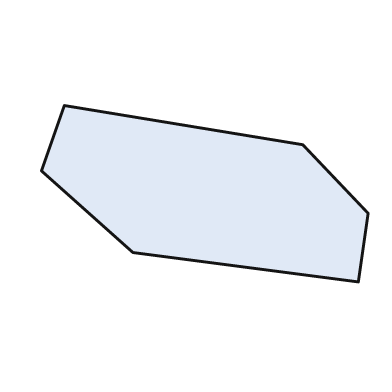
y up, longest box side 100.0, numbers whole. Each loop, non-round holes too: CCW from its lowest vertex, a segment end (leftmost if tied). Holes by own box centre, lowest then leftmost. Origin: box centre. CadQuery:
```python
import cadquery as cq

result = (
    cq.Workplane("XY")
    .moveTo(47.0, -27.0)
    .lineTo(50.0, -6.0)
    .lineTo(30.0, 15.0)
    .lineTo(-43.0, 27.0)
    .lineTo(-50.0, 7.0)
    .lineTo(-22.0, -18.0)
    .close()
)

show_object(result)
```